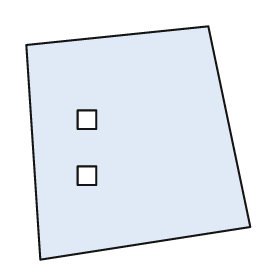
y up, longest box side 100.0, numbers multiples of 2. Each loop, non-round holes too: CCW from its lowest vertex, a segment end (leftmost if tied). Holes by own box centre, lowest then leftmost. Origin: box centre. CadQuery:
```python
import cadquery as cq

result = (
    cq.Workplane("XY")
    .moveTo(-42.0, -50.0)
    .lineTo(48.0, -36.0)
    .lineTo(30.0, 50.0)
    .lineTo(-48.0, 42.0)
    .close()
    .moveTo(-26.0, -18.0)
    .lineTo(-18.0, -18.0)
    .lineTo(-18.0, -10.0)
    .lineTo(-26.0, -10.0)
    .close()
    .moveTo(-26.0, 6.0)
    .lineTo(-18.0, 6.0)
    .lineTo(-18.0, 14.0)
    .lineTo(-26.0, 14.0)
    .close()
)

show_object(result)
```